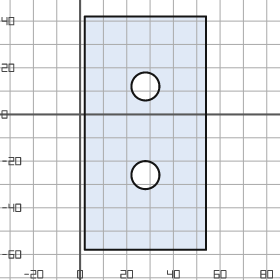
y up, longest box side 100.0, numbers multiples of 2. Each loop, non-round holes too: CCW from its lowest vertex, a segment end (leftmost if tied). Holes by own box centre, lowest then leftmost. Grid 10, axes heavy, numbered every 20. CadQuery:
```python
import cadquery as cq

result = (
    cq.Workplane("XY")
    .moveTo(2.0, -58.0)
    .lineTo(54.0, -58.0)
    .lineTo(54.0, 42.0)
    .lineTo(2.0, 42.0)
    .close()
    .moveTo(28.0, -26.0)
    .circle(6.0)
    .moveTo(28.0, 12.0)
    .circle(6.0)
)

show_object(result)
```